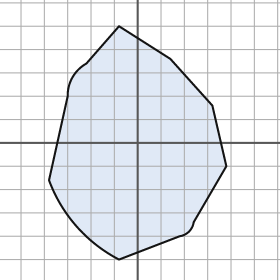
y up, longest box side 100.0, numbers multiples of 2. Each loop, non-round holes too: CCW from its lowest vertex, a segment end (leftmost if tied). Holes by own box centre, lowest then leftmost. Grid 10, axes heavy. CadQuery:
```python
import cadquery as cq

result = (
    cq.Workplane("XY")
    .moveTo(-8.0, -50.0)
    .lineTo(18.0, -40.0)
    .threePointArc((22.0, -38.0), (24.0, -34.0))
    .lineTo(38.0, -10.0)
    .lineTo(32.0, 16.0)
    .lineTo(14.0, 36.0)
    .lineTo(-8.0, 50.0)
    .lineTo(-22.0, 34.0)
    .threePointArc((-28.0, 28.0), (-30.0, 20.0))
    .lineTo(-38.0, -16.0)
    .threePointArc((-26.0, -36.0), (-8.0, -50.0))
    .close()
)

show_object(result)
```